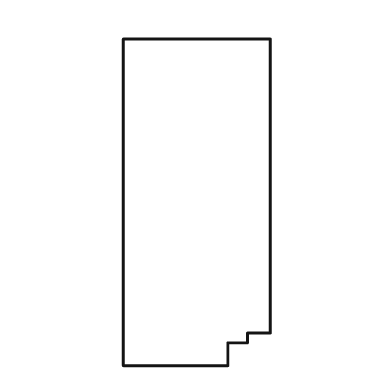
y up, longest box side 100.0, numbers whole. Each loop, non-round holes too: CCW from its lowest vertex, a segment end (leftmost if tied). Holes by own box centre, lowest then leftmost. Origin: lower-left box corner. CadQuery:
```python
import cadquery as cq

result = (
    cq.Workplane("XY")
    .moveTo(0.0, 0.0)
    .lineTo(32.0, 0.0)
    .lineTo(32.0, 7.0)
    .lineTo(38.0, 7.0)
    .lineTo(38.0, 10.0)
    .lineTo(45.0, 10.0)
    .lineTo(45.0, 100.0)
    .lineTo(0.0, 100.0)
    .close()
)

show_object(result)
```